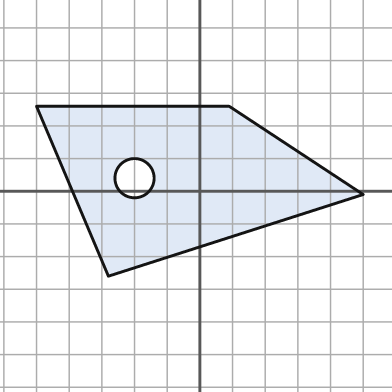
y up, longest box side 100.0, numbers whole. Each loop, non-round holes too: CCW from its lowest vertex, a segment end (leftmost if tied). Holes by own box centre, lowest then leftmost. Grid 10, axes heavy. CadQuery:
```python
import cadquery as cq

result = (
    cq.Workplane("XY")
    .moveTo(-28.0, -26.0)
    .lineTo(50.0, -1.0)
    .lineTo(9.0, 26.0)
    .lineTo(-50.0, 26.0)
    .close()
    .moveTo(-20.0, 4.0)
    .circle(6.0)
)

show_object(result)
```